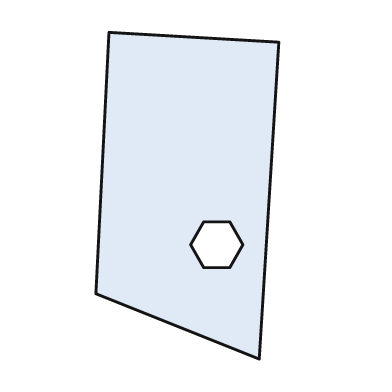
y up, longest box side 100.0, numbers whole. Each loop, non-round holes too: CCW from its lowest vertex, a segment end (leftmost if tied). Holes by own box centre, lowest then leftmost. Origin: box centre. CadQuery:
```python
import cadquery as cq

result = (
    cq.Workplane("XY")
    .moveTo(22.0, -50.0)
    .lineTo(28.0, 47.0)
    .lineTo(-24.0, 50.0)
    .lineTo(-28.0, -30.0)
    .close()
    .moveTo(5.0, -22.0)
    .lineTo(13.0, -22.0)
    .lineTo(17.0, -15.0)
    .lineTo(13.0, -8.0)
    .lineTo(5.0, -8.0)
    .lineTo(1.0, -15.0)
    .close()
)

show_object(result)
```